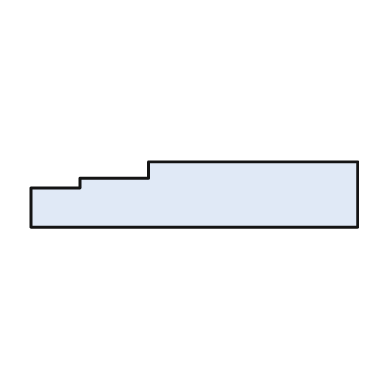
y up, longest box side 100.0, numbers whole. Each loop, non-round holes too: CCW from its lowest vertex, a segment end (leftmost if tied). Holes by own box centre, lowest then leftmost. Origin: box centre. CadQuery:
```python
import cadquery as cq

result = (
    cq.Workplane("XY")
    .moveTo(-50.0, -10.0)
    .lineTo(50.0, -10.0)
    .lineTo(50.0, 10.0)
    .lineTo(-14.0, 10.0)
    .lineTo(-14.0, 5.0)
    .lineTo(-35.0, 5.0)
    .lineTo(-35.0, 2.0)
    .lineTo(-50.0, 2.0)
    .close()
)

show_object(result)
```